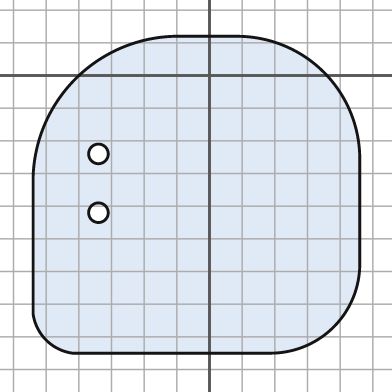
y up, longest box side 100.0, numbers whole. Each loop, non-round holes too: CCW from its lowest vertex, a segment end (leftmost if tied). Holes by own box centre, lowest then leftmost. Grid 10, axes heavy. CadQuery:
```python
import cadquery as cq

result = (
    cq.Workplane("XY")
    .moveTo(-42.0, -85.0)
    .lineTo(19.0, -85.0)
    .threePointArc((38.0, -77.0), (46.0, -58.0))
    .lineTo(46.0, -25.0)
    .threePointArc((35.0, 1.0), (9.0, 12.0))
    .lineTo(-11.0, 12.0)
    .threePointArc((-41.0, -1.0), (-54.0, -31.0))
    .lineTo(-54.0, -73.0)
    .threePointArc((-50.0, -81.0), (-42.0, -85.0))
    .close()
    .moveTo(-34.0, -42.0)
    .circle(3.0)
    .moveTo(-34.0, -24.0)
    .circle(3.0)
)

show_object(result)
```